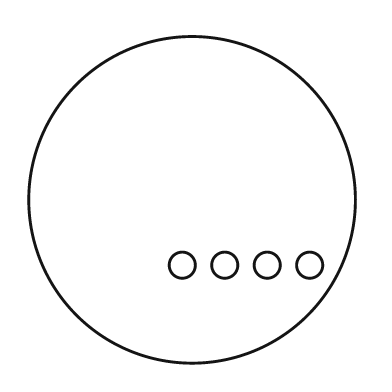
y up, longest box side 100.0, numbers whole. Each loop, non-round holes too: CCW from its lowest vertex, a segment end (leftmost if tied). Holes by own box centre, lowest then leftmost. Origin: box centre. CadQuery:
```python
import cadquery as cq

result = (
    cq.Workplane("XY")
    .moveTo(0.0, 0.0)
    .circle(50.0)
    .moveTo(-3.0, -20.0)
    .circle(4.0)
    .moveTo(10.0, -20.0)
    .circle(4.0)
    .moveTo(23.0, -20.0)
    .circle(4.0)
    .moveTo(36.0, -20.0)
    .circle(4.0)
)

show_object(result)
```